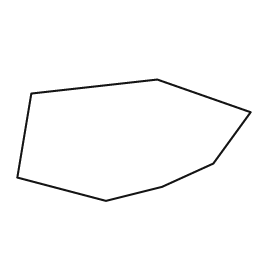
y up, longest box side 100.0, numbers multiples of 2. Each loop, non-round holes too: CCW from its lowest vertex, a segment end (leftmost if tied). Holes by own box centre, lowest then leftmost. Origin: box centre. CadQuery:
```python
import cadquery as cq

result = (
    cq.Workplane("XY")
    .moveTo(-12.0, -26.0)
    .lineTo(12.0, -20.0)
    .lineTo(34.0, -10.0)
    .lineTo(50.0, 12.0)
    .lineTo(10.0, 26.0)
    .lineTo(-44.0, 20.0)
    .lineTo(-50.0, -16.0)
    .close()
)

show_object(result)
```